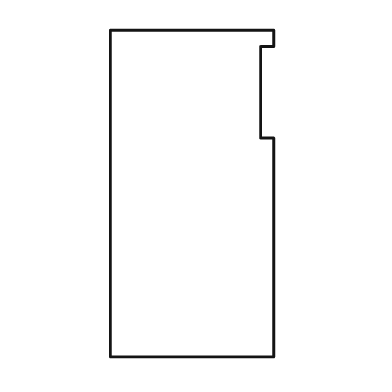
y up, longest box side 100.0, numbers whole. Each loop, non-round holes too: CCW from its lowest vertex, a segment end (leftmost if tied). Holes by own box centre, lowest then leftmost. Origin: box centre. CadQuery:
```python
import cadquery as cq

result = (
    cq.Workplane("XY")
    .moveTo(-25.0, -50.0)
    .lineTo(25.0, -50.0)
    .lineTo(25.0, 17.0)
    .lineTo(21.0, 17.0)
    .lineTo(21.0, 45.0)
    .lineTo(25.0, 45.0)
    .lineTo(25.0, 50.0)
    .lineTo(-25.0, 50.0)
    .close()
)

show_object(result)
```